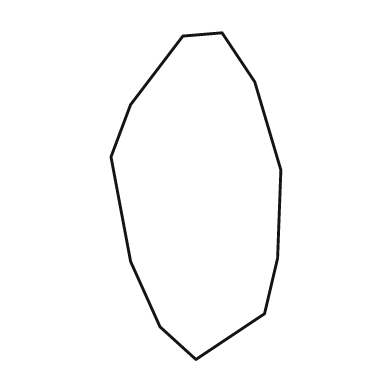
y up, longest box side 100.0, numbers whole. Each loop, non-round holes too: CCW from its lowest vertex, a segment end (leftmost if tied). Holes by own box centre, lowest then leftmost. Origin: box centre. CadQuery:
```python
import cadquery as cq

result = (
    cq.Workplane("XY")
    .moveTo(0.0, -50.0)
    .lineTo(21.0, -36.0)
    .lineTo(25.0, -19.0)
    .lineTo(26.0, 8.0)
    .lineTo(18.0, 35.0)
    .lineTo(8.0, 50.0)
    .lineTo(-4.0, 49.0)
    .lineTo(-20.0, 28.0)
    .lineTo(-26.0, 12.0)
    .lineTo(-20.0, -20.0)
    .lineTo(-11.0, -40.0)
    .close()
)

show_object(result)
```